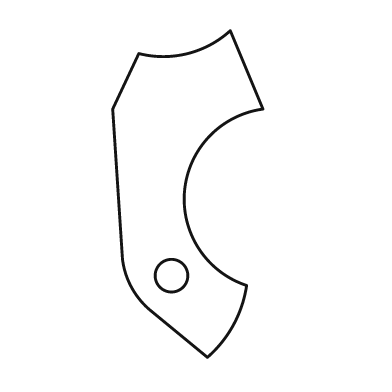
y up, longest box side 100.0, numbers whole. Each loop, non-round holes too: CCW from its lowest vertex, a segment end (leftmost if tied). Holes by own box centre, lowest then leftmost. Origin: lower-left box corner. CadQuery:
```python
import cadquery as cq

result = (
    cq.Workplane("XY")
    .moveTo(29.0, 0.0)
    .threePointArc((37.0, 10.0), (41.0, 22.0))
    .threePointArc((22.0, 51.0), (46.0, 76.0))
    .lineTo(36.0, 100.0)
    .threePointArc((23.0, 93.0), (8.0, 93.0))
    .lineTo(0.0, 76.0)
    .lineTo(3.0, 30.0)
    .threePointArc((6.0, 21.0), (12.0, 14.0))
    .close()
    .moveTo(18.0, 25.0)
    .circle(5.0)
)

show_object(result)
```